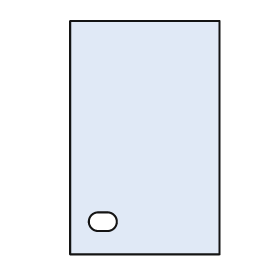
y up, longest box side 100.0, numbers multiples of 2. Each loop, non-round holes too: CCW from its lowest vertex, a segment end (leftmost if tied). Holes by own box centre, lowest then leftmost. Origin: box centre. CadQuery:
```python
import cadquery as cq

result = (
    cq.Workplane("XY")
    .moveTo(-32.0, -50.0)
    .lineTo(32.0, -50.0)
    .lineTo(32.0, 50.0)
    .lineTo(-32.0, 50.0)
    .close()
    .moveTo(-20.0, -40.0)
    .lineTo(-16.0, -40.0)
    .threePointArc((-12.0, -36.0), (-16.0, -32.0))
    .lineTo(-20.0, -32.0)
    .threePointArc((-24.0, -36.0), (-20.0, -40.0))
    .close()
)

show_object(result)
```